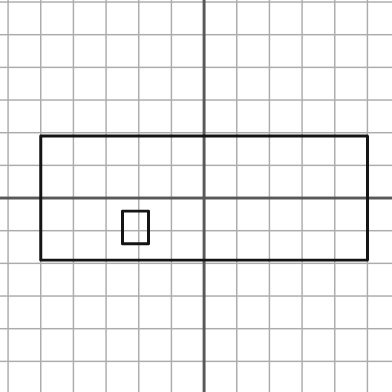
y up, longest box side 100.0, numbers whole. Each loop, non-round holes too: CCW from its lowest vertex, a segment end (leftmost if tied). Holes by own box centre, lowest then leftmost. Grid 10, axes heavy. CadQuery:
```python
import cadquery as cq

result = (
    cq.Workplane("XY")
    .moveTo(-50.0, -19.0)
    .lineTo(50.0, -19.0)
    .lineTo(50.0, 19.0)
    .lineTo(-50.0, 19.0)
    .close()
    .moveTo(-25.0, -14.0)
    .lineTo(-17.0, -14.0)
    .lineTo(-17.0, -4.0)
    .lineTo(-25.0, -4.0)
    .close()
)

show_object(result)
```